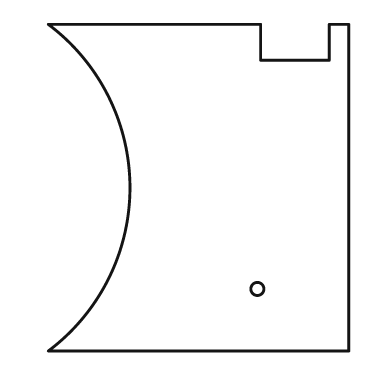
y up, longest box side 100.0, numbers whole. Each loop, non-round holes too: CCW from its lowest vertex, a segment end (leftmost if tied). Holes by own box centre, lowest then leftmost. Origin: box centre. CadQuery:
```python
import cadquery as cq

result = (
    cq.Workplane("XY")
    .moveTo(-46.0, -50.0)
    .lineTo(46.0, -50.0)
    .lineTo(46.0, 50.0)
    .lineTo(40.0, 50.0)
    .lineTo(40.0, 39.0)
    .lineTo(19.0, 39.0)
    .lineTo(19.0, 50.0)
    .lineTo(-46.0, 50.0)
    .threePointArc((-21.0, 0.0), (-46.0, -50.0))
    .close()
    .moveTo(18.0, -31.0)
    .circle(2.0)
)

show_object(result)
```